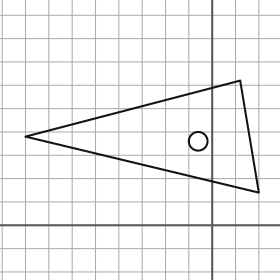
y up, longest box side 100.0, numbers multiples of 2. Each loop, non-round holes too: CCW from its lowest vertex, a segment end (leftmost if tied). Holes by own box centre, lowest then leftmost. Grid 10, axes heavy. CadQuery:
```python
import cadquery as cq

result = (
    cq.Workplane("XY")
    .moveTo(20.0, 14.0)
    .lineTo(12.0, 62.0)
    .lineTo(-80.0, 38.0)
    .close()
    .moveTo(-6.0, 36.0)
    .circle(4.0)
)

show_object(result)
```